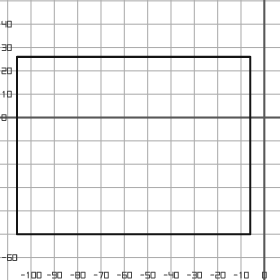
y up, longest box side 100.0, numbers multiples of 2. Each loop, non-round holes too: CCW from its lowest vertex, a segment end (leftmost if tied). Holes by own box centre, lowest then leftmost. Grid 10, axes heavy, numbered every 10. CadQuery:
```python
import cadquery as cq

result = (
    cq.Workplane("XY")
    .moveTo(-106.0, -50.0)
    .lineTo(-6.0, -50.0)
    .lineTo(-6.0, 26.0)
    .lineTo(-106.0, 26.0)
    .close()
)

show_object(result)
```